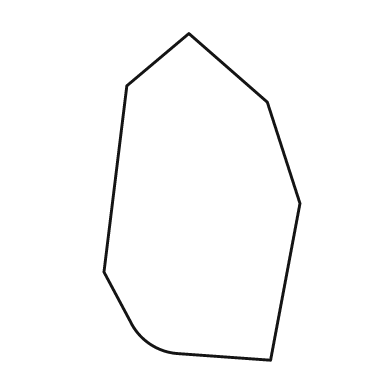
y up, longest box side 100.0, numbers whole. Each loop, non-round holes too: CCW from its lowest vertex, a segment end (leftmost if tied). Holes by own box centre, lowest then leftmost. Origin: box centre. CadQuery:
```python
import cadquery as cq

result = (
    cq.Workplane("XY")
    .moveTo(21.0, -50.0)
    .lineTo(30.0, -2.0)
    .lineTo(20.0, 29.0)
    .lineTo(-4.0, 50.0)
    .lineTo(-23.0, 34.0)
    .lineTo(-30.0, -23.0)
    .lineTo(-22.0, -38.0)
    .threePointArc((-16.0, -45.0), (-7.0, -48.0))
    .close()
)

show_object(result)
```